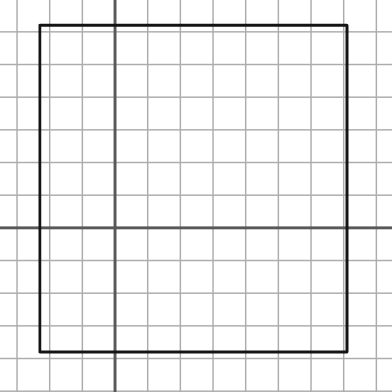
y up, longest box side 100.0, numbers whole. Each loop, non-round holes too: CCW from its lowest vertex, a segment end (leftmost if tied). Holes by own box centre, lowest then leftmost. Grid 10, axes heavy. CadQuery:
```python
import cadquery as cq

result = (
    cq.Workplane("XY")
    .moveTo(-23.0, -38.0)
    .lineTo(71.0, -38.0)
    .lineTo(71.0, 62.0)
    .lineTo(-23.0, 62.0)
    .close()
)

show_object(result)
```